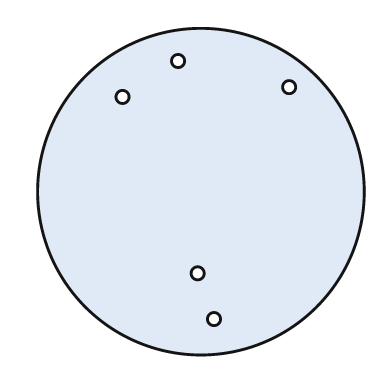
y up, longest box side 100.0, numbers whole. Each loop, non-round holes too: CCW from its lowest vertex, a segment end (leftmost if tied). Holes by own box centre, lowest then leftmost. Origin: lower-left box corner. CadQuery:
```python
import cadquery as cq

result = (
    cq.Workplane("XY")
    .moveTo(50.0, 50.0)
    .circle(50.0)
    .moveTo(54.0, 11.0)
    .circle(2.0)
    .moveTo(49.0, 25.0)
    .circle(2.0)
    .moveTo(26.0, 79.0)
    .circle(2.0)
    .moveTo(77.0, 82.0)
    .circle(2.0)
    .moveTo(43.0, 90.0)
    .circle(2.0)
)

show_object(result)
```